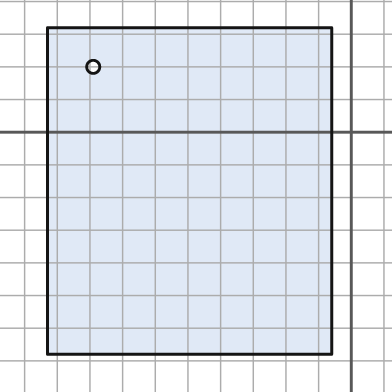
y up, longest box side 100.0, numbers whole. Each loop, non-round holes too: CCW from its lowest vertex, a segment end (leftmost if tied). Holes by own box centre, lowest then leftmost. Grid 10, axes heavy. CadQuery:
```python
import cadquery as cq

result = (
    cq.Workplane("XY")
    .moveTo(-93.0, -68.0)
    .lineTo(-6.0, -68.0)
    .lineTo(-6.0, 32.0)
    .lineTo(-93.0, 32.0)
    .close()
    .moveTo(-79.0, 20.0)
    .circle(2.0)
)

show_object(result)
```